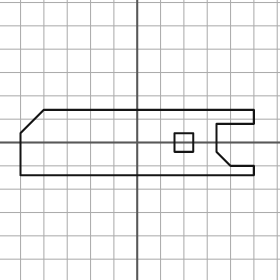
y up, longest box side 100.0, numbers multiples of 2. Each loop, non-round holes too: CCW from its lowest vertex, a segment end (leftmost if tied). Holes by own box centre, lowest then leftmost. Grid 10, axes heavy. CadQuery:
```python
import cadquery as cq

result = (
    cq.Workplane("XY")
    .moveTo(-50.0, -14.0)
    .lineTo(50.0, -14.0)
    .lineTo(50.0, -10.0)
    .lineTo(40.0, -10.0)
    .lineTo(34.0, -4.0)
    .lineTo(34.0, 8.0)
    .lineTo(50.0, 8.0)
    .lineTo(50.0, 14.0)
    .lineTo(-40.0, 14.0)
    .lineTo(-50.0, 4.0)
    .close()
    .moveTo(16.0, -4.0)
    .lineTo(24.0, -4.0)
    .lineTo(24.0, 4.0)
    .lineTo(16.0, 4.0)
    .close()
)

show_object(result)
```